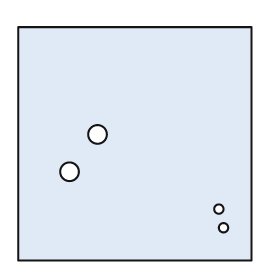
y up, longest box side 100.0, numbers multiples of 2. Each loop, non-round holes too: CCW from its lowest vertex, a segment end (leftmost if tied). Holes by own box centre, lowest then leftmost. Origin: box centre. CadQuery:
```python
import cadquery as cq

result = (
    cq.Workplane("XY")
    .moveTo(-50.0, -50.0)
    .lineTo(50.0, -50.0)
    .lineTo(50.0, 50.0)
    .lineTo(-50.0, 50.0)
    .close()
    .moveTo(38.0, -36.0)
    .circle(2.0)
    .moveTo(36.0, -28.0)
    .circle(2.0)
    .moveTo(-28.0, -12.0)
    .circle(4.0)
    .moveTo(-16.0, 4.0)
    .circle(4.0)
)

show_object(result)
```